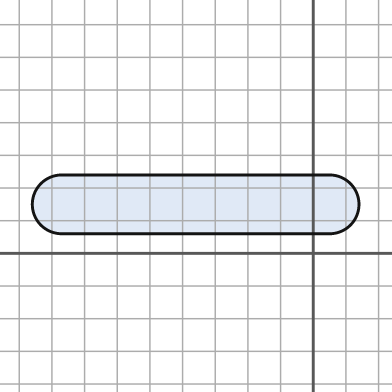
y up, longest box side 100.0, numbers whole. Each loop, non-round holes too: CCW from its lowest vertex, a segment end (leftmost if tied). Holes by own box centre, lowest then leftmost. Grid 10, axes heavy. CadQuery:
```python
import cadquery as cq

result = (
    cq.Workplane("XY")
    .moveTo(-77.0, 6.0)
    .lineTo(5.0, 6.0)
    .threePointArc((14.0, 15.0), (5.0, 24.0))
    .lineTo(-77.0, 24.0)
    .threePointArc((-86.0, 15.0), (-77.0, 6.0))
    .close()
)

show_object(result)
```